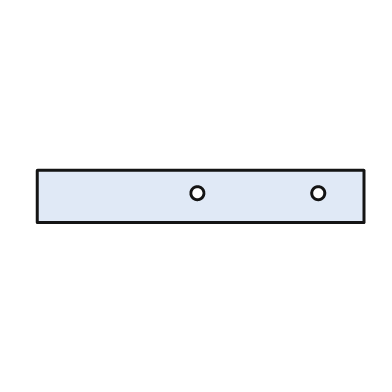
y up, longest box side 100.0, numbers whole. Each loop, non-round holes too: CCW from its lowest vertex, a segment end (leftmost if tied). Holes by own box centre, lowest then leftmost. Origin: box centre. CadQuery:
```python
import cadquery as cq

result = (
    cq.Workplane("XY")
    .moveTo(-50.0, -8.0)
    .lineTo(50.0, -8.0)
    .lineTo(50.0, 8.0)
    .lineTo(-50.0, 8.0)
    .close()
    .moveTo(-1.0, 1.0)
    .circle(2.0)
    .moveTo(36.0, 1.0)
    .circle(2.0)
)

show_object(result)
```